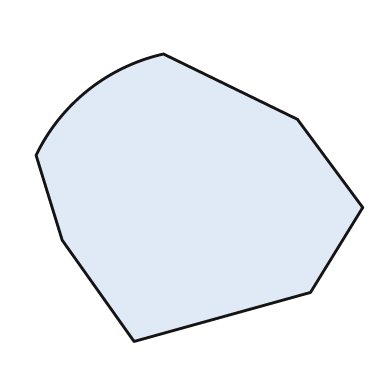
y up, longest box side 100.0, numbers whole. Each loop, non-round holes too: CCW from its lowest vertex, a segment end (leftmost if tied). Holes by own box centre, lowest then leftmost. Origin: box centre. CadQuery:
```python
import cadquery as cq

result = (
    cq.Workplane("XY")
    .moveTo(-20.0, -44.0)
    .lineTo(34.0, -29.0)
    .lineTo(50.0, -3.0)
    .lineTo(30.0, 24.0)
    .lineTo(-11.0, 44.0)
    .threePointArc((-34.0, 33.0), (-50.0, 13.0))
    .lineTo(-42.0, -13.0)
    .close()
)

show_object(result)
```